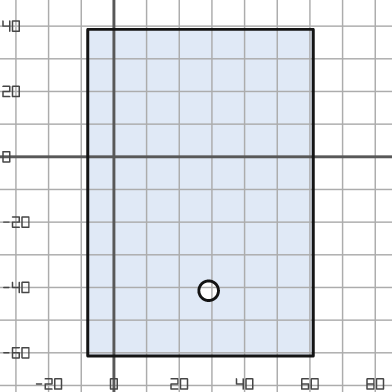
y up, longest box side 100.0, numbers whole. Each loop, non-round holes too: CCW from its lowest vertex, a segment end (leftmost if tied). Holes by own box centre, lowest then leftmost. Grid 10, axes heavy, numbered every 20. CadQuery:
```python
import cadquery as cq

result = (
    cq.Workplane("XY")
    .moveTo(-8.0, -61.0)
    .lineTo(61.0, -61.0)
    .lineTo(61.0, 39.0)
    .lineTo(-8.0, 39.0)
    .close()
    .moveTo(29.0, -41.0)
    .circle(3.0)
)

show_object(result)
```